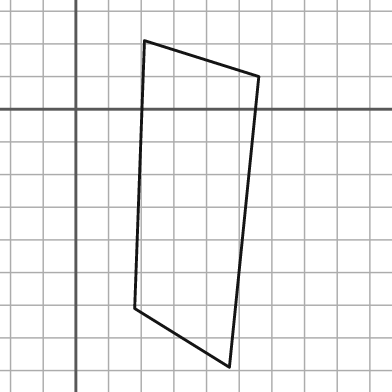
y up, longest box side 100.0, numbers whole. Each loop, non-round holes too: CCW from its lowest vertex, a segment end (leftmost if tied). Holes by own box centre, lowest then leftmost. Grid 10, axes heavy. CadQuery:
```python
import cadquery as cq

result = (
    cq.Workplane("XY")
    .moveTo(47.0, -79.0)
    .lineTo(56.0, 10.0)
    .lineTo(21.0, 21.0)
    .lineTo(18.0, -61.0)
    .close()
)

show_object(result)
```